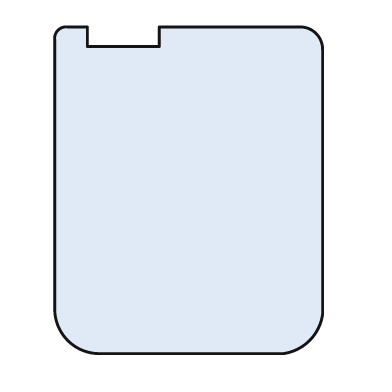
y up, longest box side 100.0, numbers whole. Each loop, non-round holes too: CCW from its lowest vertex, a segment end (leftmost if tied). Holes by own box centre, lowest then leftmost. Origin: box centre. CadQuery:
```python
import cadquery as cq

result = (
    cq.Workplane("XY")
    .moveTo(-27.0, -50.0)
    .lineTo(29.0, -50.0)
    .threePointArc((37.0, -46.0), (41.0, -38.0))
    .lineTo(41.0, 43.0)
    .threePointArc((39.0, 48.0), (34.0, 50.0))
    .lineTo(-9.0, 50.0)
    .lineTo(-9.0, 44.0)
    .lineTo(-31.0, 44.0)
    .lineTo(-31.0, 50.0)
    .lineTo(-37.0, 50.0)
    .threePointArc((-40.0, 49.0), (-41.0, 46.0))
    .lineTo(-41.0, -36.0)
    .threePointArc((-37.0, -46.0), (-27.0, -50.0))
    .close()
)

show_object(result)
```